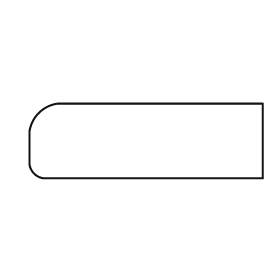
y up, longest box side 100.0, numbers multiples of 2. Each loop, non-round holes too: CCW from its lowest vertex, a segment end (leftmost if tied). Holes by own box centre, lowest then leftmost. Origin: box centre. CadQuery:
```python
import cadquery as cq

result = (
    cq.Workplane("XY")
    .moveTo(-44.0, -16.0)
    .lineTo(50.0, -16.0)
    .lineTo(50.0, 16.0)
    .lineTo(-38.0, 16.0)
    .threePointArc((-46.0, 12.0), (-50.0, 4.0))
    .lineTo(-50.0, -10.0)
    .threePointArc((-48.0, -14.0), (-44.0, -16.0))
    .close()
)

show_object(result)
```